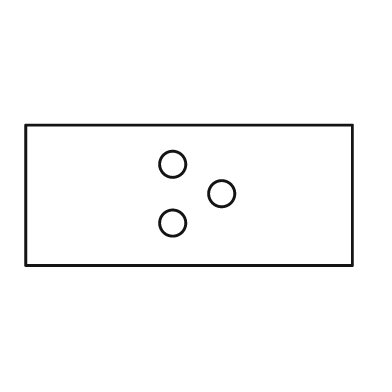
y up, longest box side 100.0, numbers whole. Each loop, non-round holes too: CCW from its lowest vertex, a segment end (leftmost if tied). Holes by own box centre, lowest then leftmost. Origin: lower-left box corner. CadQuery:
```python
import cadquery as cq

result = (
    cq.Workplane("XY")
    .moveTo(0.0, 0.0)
    .lineTo(100.0, 0.0)
    .lineTo(100.0, 43.0)
    .lineTo(0.0, 43.0)
    .close()
    .moveTo(45.0, 13.0)
    .circle(4.0)
    .moveTo(60.0, 22.0)
    .circle(4.0)
    .moveTo(45.0, 31.0)
    .circle(4.0)
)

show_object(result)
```